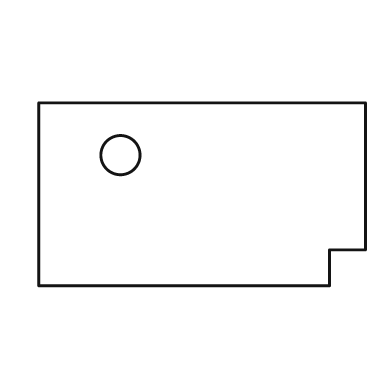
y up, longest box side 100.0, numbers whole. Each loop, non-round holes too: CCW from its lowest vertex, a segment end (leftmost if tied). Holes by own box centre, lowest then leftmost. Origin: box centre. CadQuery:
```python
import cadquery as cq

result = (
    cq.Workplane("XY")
    .moveTo(-50.0, -28.0)
    .lineTo(39.0, -28.0)
    .lineTo(39.0, -17.0)
    .lineTo(50.0, -17.0)
    .lineTo(50.0, 28.0)
    .lineTo(-50.0, 28.0)
    .close()
    .moveTo(-25.0, 12.0)
    .circle(6.0)
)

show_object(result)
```